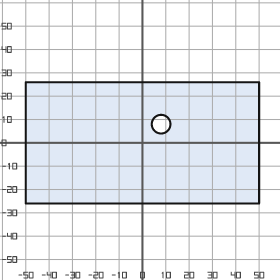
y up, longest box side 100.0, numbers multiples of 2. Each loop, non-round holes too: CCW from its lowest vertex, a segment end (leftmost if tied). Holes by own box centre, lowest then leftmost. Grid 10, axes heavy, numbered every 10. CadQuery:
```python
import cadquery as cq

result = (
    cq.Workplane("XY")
    .moveTo(-50.0, -26.0)
    .lineTo(50.0, -26.0)
    .lineTo(50.0, 26.0)
    .lineTo(-50.0, 26.0)
    .close()
    .moveTo(8.0, 8.0)
    .circle(4.0)
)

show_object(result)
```